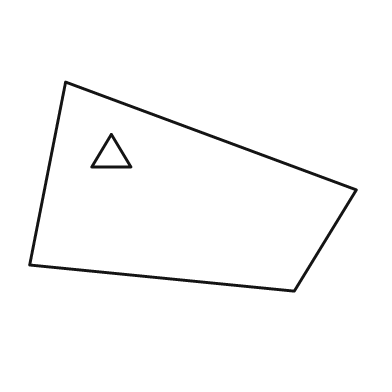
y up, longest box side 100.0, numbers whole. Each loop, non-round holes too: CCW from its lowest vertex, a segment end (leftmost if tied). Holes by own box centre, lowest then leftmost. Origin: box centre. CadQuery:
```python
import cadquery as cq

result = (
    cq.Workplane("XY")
    .moveTo(31.0, -32.0)
    .lineTo(50.0, -1.0)
    .lineTo(-39.0, 32.0)
    .lineTo(-50.0, -24.0)
    .close()
    .moveTo(-31.0, 6.0)
    .lineTo(-19.0, 6.0)
    .lineTo(-25.0, 16.0)
    .close()
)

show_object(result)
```